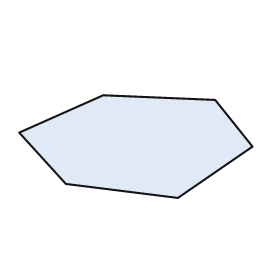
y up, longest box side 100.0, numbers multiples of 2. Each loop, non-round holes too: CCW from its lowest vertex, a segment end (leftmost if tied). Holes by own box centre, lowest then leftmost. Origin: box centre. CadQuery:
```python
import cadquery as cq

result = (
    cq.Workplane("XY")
    .moveTo(18.0, -22.0)
    .lineTo(50.0, 0.0)
    .lineTo(34.0, 20.0)
    .lineTo(-14.0, 22.0)
    .lineTo(-50.0, 6.0)
    .lineTo(-30.0, -16.0)
    .close()
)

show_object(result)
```